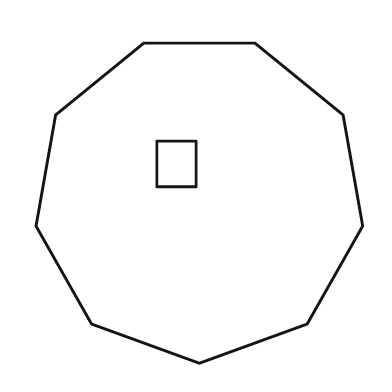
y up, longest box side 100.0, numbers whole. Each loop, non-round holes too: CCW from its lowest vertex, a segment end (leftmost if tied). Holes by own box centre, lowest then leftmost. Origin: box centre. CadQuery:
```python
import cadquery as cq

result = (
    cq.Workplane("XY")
    .moveTo(0.0, -49.0)
    .lineTo(33.0, -37.0)
    .lineTo(50.0, -7.0)
    .lineTo(44.0, 27.0)
    .lineTo(17.0, 49.0)
    .lineTo(-17.0, 49.0)
    .lineTo(-44.0, 27.0)
    .lineTo(-50.0, -7.0)
    .lineTo(-33.0, -37.0)
    .close()
    .moveTo(-13.0, 5.0)
    .lineTo(-1.0, 5.0)
    .lineTo(-1.0, 19.0)
    .lineTo(-13.0, 19.0)
    .close()
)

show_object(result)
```